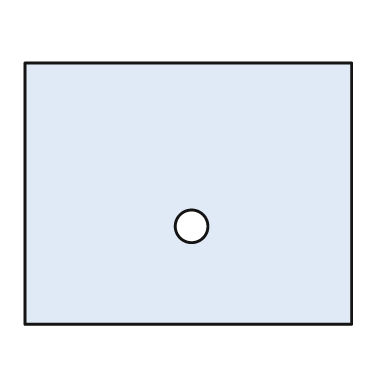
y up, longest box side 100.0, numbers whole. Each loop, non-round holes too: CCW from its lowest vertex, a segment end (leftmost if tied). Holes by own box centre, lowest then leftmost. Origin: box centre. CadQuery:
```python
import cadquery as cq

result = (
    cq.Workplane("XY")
    .moveTo(-50.0, -40.0)
    .lineTo(50.0, -40.0)
    .lineTo(50.0, 40.0)
    .lineTo(-50.0, 40.0)
    .close()
    .moveTo(1.0, -10.0)
    .circle(5.0)
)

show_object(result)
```